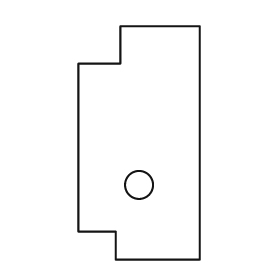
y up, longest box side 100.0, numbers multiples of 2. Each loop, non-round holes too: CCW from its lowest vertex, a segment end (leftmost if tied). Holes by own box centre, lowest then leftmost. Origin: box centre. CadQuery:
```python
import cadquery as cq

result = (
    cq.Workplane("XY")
    .moveTo(-10.0, -50.0)
    .lineTo(26.0, -50.0)
    .lineTo(26.0, 50.0)
    .lineTo(-8.0, 50.0)
    .lineTo(-8.0, 34.0)
    .lineTo(-26.0, 34.0)
    .lineTo(-26.0, -38.0)
    .lineTo(-10.0, -38.0)
    .close()
    .moveTo(0.0, -18.0)
    .circle(6.0)
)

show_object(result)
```